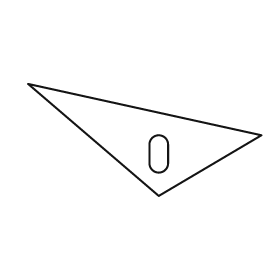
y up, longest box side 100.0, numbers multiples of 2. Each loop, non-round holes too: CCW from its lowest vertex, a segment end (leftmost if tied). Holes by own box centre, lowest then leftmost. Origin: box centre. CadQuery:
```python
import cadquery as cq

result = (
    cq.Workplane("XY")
    .moveTo(6.0, -24.0)
    .lineTo(50.0, 2.0)
    .lineTo(-50.0, 24.0)
    .close()
    .moveTo(2.0, -10.0)
    .threePointArc((6.0, -14.0), (10.0, -10.0))
    .lineTo(10.0, -2.0)
    .threePointArc((6.0, 2.0), (2.0, -2.0))
    .close()
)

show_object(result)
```